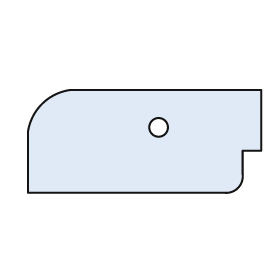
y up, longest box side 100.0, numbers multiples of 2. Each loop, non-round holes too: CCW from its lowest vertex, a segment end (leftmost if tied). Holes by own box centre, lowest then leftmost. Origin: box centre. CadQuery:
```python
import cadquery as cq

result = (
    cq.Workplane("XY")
    .moveTo(-50.0, -22.0)
    .lineTo(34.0, -22.0)
    .threePointArc((40.0, -20.0), (42.0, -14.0))
    .lineTo(42.0, -4.0)
    .lineTo(50.0, -4.0)
    .lineTo(50.0, 22.0)
    .lineTo(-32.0, 22.0)
    .threePointArc((-44.0, 16.0), (-50.0, 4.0))
    .close()
    .moveTo(6.0, 6.0)
    .circle(4.0)
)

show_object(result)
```